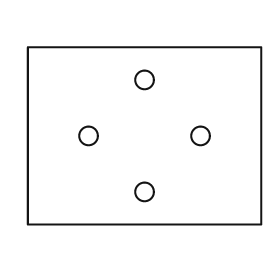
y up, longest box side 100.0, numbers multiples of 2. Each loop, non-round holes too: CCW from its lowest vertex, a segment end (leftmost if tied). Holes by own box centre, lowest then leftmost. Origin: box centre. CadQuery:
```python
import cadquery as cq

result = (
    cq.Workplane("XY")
    .moveTo(-50.0, -38.0)
    .lineTo(50.0, -38.0)
    .lineTo(50.0, 38.0)
    .lineTo(-50.0, 38.0)
    .close()
    .moveTo(0.0, -24.0)
    .circle(4.0)
    .moveTo(-24.0, 0.0)
    .circle(4.0)
    .moveTo(24.0, 0.0)
    .circle(4.0)
    .moveTo(0.0, 24.0)
    .circle(4.0)
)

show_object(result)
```